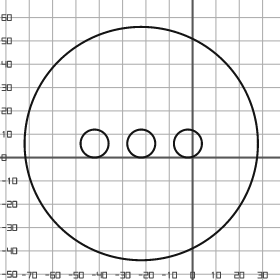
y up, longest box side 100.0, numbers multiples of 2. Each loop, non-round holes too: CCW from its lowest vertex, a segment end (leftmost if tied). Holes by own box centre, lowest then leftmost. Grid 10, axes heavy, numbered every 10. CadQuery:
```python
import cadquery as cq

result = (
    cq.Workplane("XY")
    .moveTo(-22.0, 6.0)
    .circle(50.0)
    .moveTo(-42.0, 6.0)
    .circle(6.0)
    .moveTo(-22.0, 6.0)
    .circle(6.0)
    .moveTo(-2.0, 6.0)
    .circle(6.0)
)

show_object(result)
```